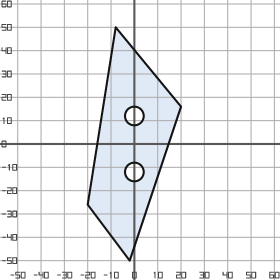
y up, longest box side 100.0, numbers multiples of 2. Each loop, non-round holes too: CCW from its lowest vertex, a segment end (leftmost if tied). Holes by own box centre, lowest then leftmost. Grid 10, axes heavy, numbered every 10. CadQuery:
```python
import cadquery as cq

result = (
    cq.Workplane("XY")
    .moveTo(-2.0, -50.0)
    .lineTo(20.0, 16.0)
    .lineTo(-8.0, 50.0)
    .lineTo(-20.0, -26.0)
    .close()
    .moveTo(0.0, -12.0)
    .circle(4.0)
    .moveTo(0.0, 12.0)
    .circle(4.0)
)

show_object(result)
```